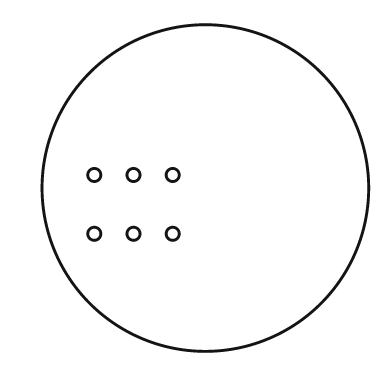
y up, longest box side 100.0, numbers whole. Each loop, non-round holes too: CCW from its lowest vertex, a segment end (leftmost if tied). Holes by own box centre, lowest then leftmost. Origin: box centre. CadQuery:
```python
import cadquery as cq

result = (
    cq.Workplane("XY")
    .moveTo(0.0, 0.0)
    .circle(50.0)
    .moveTo(-34.0, -14.0)
    .circle(2.0)
    .moveTo(-22.0, -14.0)
    .circle(2.0)
    .moveTo(-10.0, -14.0)
    .circle(2.0)
    .moveTo(-34.0, 4.0)
    .circle(2.0)
    .moveTo(-22.0, 4.0)
    .circle(2.0)
    .moveTo(-10.0, 4.0)
    .circle(2.0)
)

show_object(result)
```